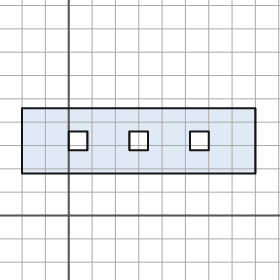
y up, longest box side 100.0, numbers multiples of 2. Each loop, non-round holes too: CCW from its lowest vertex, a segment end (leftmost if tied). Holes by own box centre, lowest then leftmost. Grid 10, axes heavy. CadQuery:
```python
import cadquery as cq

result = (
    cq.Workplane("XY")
    .moveTo(-20.0, 18.0)
    .lineTo(80.0, 18.0)
    .lineTo(80.0, 46.0)
    .lineTo(-20.0, 46.0)
    .close()
    .moveTo(0.0, 28.0)
    .lineTo(8.0, 28.0)
    .lineTo(8.0, 36.0)
    .lineTo(0.0, 36.0)
    .close()
    .moveTo(26.0, 28.0)
    .lineTo(34.0, 28.0)
    .lineTo(34.0, 36.0)
    .lineTo(26.0, 36.0)
    .close()
    .moveTo(52.0, 28.0)
    .lineTo(60.0, 28.0)
    .lineTo(60.0, 36.0)
    .lineTo(52.0, 36.0)
    .close()
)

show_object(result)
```